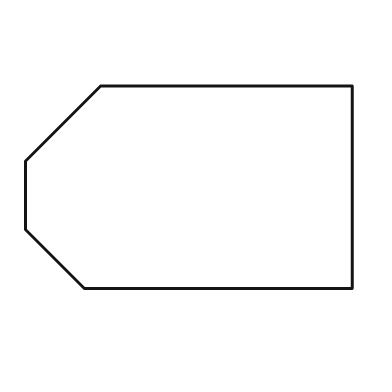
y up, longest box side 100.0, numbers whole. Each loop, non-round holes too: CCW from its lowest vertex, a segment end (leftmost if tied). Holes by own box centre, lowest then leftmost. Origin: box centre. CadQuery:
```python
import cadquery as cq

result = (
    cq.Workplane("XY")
    .moveTo(-32.0, -31.0)
    .lineTo(50.0, -31.0)
    .lineTo(50.0, 31.0)
    .lineTo(-27.0, 31.0)
    .lineTo(-50.0, 8.0)
    .lineTo(-50.0, -13.0)
    .close()
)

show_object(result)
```